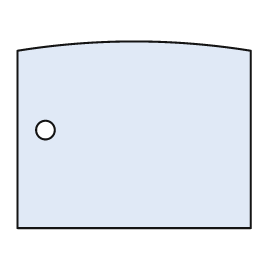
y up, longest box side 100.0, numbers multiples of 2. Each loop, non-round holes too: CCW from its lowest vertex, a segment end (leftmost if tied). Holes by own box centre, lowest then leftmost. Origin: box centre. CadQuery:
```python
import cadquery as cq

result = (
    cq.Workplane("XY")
    .moveTo(-50.0, -40.0)
    .lineTo(50.0, -40.0)
    .lineTo(50.0, 36.0)
    .threePointArc((0.0, 40.0), (-50.0, 36.0))
    .close()
    .moveTo(-38.0, 2.0)
    .circle(4.0)
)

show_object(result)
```